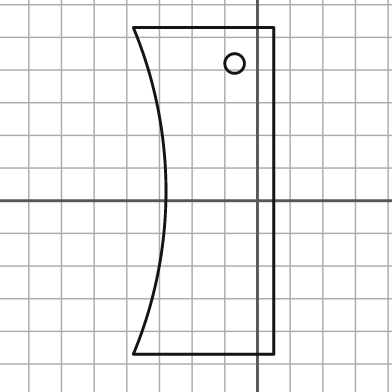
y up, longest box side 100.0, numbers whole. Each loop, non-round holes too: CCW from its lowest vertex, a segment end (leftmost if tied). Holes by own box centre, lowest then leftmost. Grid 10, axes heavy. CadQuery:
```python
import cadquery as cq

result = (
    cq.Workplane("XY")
    .moveTo(-38.0, -47.0)
    .lineTo(5.0, -47.0)
    .lineTo(5.0, 53.0)
    .lineTo(-38.0, 53.0)
    .threePointArc((-28.0, 3.0), (-38.0, -47.0))
    .close()
    .moveTo(-7.0, 42.0)
    .circle(3.0)
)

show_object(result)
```